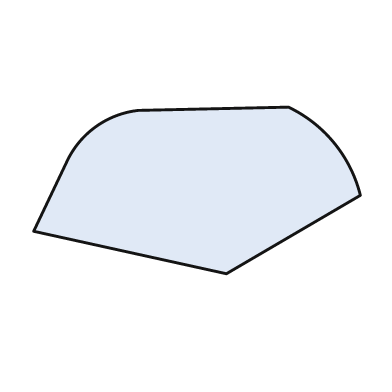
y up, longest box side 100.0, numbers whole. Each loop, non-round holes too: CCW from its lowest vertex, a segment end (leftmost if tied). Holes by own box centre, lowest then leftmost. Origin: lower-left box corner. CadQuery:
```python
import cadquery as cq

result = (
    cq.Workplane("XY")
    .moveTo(59.0, 0.0)
    .lineTo(100.0, 24.0)
    .threePointArc((92.0, 40.0), (78.0, 51.0))
    .lineTo(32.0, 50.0)
    .threePointArc((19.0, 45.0), (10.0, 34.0))
    .lineTo(0.0, 13.0)
    .close()
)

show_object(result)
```